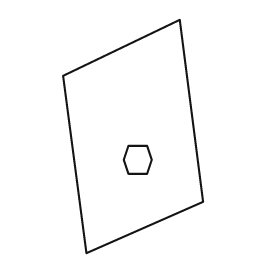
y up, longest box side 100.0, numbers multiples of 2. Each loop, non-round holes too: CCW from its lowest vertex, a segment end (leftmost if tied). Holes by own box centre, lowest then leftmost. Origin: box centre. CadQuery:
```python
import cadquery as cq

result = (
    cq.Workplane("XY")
    .moveTo(-20.0, -50.0)
    .lineTo(30.0, -28.0)
    .lineTo(20.0, 50.0)
    .lineTo(-30.0, 26.0)
    .close()
    .moveTo(-2.0, -16.0)
    .lineTo(6.0, -16.0)
    .lineTo(8.0, -10.0)
    .lineTo(6.0, -4.0)
    .lineTo(-2.0, -4.0)
    .lineTo(-4.0, -10.0)
    .close()
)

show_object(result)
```